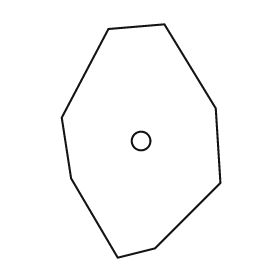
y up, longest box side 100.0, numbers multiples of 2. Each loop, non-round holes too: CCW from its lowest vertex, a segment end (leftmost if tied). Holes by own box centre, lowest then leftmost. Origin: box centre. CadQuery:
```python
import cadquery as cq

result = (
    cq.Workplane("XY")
    .moveTo(-10.0, -50.0)
    .lineTo(6.0, -46.0)
    .lineTo(34.0, -18.0)
    .lineTo(32.0, 14.0)
    .lineTo(10.0, 50.0)
    .lineTo(-14.0, 48.0)
    .lineTo(-34.0, 10.0)
    .lineTo(-30.0, -16.0)
    .close()
    .moveTo(0.0, 0.0)
    .circle(4.0)
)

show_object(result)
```